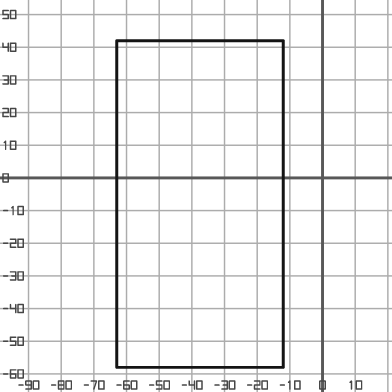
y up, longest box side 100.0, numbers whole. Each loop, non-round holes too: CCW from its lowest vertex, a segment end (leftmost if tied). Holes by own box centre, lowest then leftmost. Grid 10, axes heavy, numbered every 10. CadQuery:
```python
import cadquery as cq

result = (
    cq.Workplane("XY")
    .moveTo(-63.0, -58.0)
    .lineTo(-12.0, -58.0)
    .lineTo(-12.0, 42.0)
    .lineTo(-63.0, 42.0)
    .close()
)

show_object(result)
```